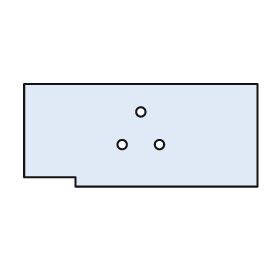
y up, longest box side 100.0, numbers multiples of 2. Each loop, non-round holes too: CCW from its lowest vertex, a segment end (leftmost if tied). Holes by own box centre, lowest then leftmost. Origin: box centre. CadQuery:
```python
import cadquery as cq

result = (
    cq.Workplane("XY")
    .moveTo(-28.0, -22.0)
    .lineTo(50.0, -22.0)
    .lineTo(50.0, 22.0)
    .lineTo(-50.0, 22.0)
    .lineTo(-50.0, -18.0)
    .lineTo(-28.0, -18.0)
    .close()
    .moveTo(-8.0, -4.0)
    .circle(2.0)
    .moveTo(8.0, -4.0)
    .circle(2.0)
    .moveTo(0.0, 10.0)
    .circle(2.0)
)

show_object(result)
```